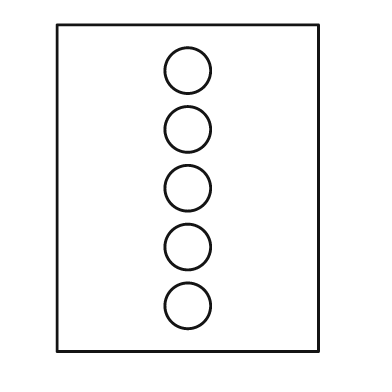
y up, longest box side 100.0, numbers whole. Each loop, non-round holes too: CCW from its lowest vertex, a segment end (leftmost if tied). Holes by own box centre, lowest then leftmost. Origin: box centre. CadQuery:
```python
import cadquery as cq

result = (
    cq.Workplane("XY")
    .moveTo(-40.0, -50.0)
    .lineTo(40.0, -50.0)
    .lineTo(40.0, 50.0)
    .lineTo(-40.0, 50.0)
    .close()
    .moveTo(0.0, -36.0)
    .circle(7.0)
    .moveTo(0.0, -18.0)
    .circle(7.0)
    .moveTo(0.0, 0.0)
    .circle(7.0)
    .moveTo(0.0, 18.0)
    .circle(7.0)
    .moveTo(0.0, 36.0)
    .circle(7.0)
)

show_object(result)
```